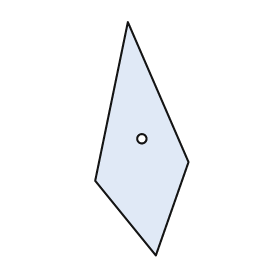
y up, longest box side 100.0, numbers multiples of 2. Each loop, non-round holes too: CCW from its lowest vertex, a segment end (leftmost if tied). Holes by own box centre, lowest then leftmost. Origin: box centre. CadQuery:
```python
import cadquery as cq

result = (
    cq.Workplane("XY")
    .moveTo(6.0, -50.0)
    .lineTo(20.0, -10.0)
    .lineTo(-6.0, 50.0)
    .lineTo(-20.0, -18.0)
    .close()
    .moveTo(0.0, 0.0)
    .circle(2.0)
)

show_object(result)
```